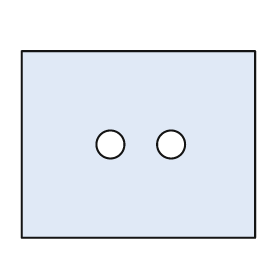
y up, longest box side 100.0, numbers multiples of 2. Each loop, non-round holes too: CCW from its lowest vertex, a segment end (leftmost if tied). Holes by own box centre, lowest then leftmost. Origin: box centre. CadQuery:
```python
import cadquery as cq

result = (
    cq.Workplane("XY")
    .moveTo(-50.0, -40.0)
    .lineTo(50.0, -40.0)
    .lineTo(50.0, 40.0)
    .lineTo(-50.0, 40.0)
    .close()
    .moveTo(-12.0, 0.0)
    .circle(6.0)
    .moveTo(14.0, 0.0)
    .circle(6.0)
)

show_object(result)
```